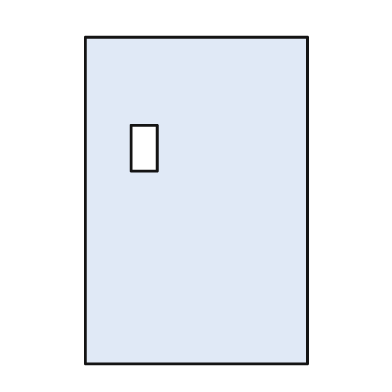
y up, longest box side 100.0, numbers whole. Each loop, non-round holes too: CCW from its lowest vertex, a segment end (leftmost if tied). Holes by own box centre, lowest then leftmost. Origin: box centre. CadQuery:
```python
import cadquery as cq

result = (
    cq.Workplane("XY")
    .moveTo(-34.0, -50.0)
    .lineTo(34.0, -50.0)
    .lineTo(34.0, 50.0)
    .lineTo(-34.0, 50.0)
    .close()
    .moveTo(-20.0, 9.0)
    .lineTo(-12.0, 9.0)
    .lineTo(-12.0, 23.0)
    .lineTo(-20.0, 23.0)
    .close()
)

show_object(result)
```